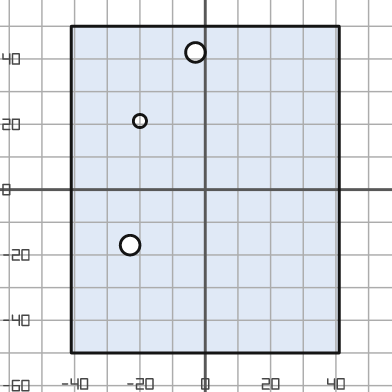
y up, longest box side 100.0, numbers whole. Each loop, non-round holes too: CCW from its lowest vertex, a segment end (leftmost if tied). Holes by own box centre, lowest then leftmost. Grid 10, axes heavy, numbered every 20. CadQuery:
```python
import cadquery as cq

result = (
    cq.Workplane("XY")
    .moveTo(-41.0, -50.0)
    .lineTo(41.0, -50.0)
    .lineTo(41.0, 50.0)
    .lineTo(-41.0, 50.0)
    .close()
    .moveTo(-23.0, -17.0)
    .circle(3.0)
    .moveTo(-20.0, 21.0)
    .circle(2.0)
    .moveTo(-3.0, 42.0)
    .circle(3.0)
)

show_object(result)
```